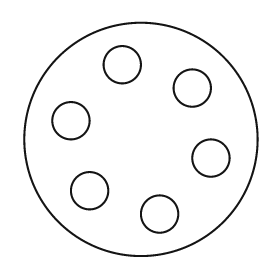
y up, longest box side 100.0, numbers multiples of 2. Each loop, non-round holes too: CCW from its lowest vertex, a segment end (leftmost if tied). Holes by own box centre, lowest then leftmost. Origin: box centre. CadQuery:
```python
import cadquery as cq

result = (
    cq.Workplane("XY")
    .moveTo(0.0, 0.0)
    .circle(50.0)
    .moveTo(8.0, -32.0)
    .circle(8.0)
    .moveTo(-22.0, -22.0)
    .circle(8.0)
    .moveTo(30.0, -8.0)
    .circle(8.0)
    .moveTo(-30.0, 8.0)
    .circle(8.0)
    .moveTo(22.0, 22.0)
    .circle(8.0)
    .moveTo(-8.0, 32.0)
    .circle(8.0)
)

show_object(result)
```